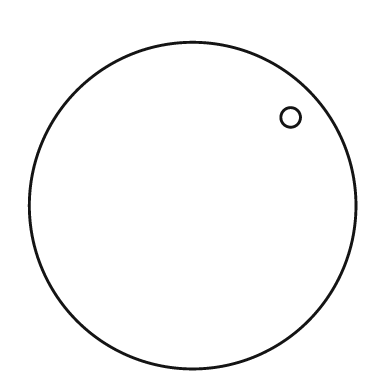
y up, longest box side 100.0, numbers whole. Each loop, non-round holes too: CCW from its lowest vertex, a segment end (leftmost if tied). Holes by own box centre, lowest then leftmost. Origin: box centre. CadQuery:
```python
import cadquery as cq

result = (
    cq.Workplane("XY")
    .moveTo(0.0, 0.0)
    .circle(50.0)
    .moveTo(30.0, 27.0)
    .circle(3.0)
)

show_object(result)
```